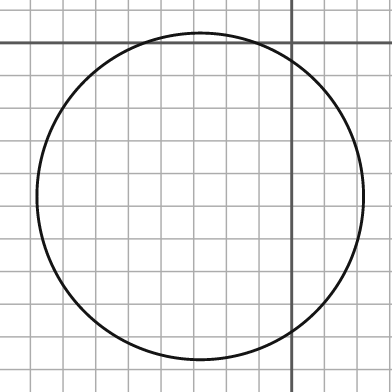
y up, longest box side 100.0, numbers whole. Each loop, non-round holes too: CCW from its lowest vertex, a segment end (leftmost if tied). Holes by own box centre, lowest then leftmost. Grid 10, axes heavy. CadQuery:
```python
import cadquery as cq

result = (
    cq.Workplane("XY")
    .moveTo(-28.0, -47.0)
    .circle(50.0)
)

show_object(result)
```